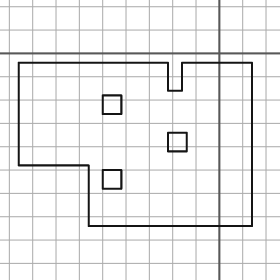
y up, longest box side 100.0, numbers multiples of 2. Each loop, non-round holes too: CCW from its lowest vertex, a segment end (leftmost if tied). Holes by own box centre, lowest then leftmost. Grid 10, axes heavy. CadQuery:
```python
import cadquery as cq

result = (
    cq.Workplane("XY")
    .moveTo(-56.0, -74.0)
    .lineTo(14.0, -74.0)
    .lineTo(14.0, -4.0)
    .lineTo(-16.0, -4.0)
    .lineTo(-16.0, -16.0)
    .lineTo(-22.0, -16.0)
    .lineTo(-22.0, -4.0)
    .lineTo(-86.0, -4.0)
    .lineTo(-86.0, -48.0)
    .lineTo(-56.0, -48.0)
    .close()
    .moveTo(-50.0, -58.0)
    .lineTo(-42.0, -58.0)
    .lineTo(-42.0, -50.0)
    .lineTo(-50.0, -50.0)
    .close()
    .moveTo(-22.0, -42.0)
    .lineTo(-14.0, -42.0)
    .lineTo(-14.0, -34.0)
    .lineTo(-22.0, -34.0)
    .close()
    .moveTo(-50.0, -26.0)
    .lineTo(-42.0, -26.0)
    .lineTo(-42.0, -18.0)
    .lineTo(-50.0, -18.0)
    .close()
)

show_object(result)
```